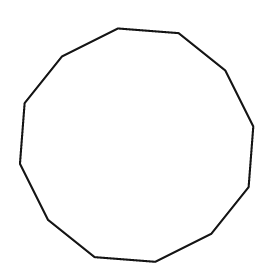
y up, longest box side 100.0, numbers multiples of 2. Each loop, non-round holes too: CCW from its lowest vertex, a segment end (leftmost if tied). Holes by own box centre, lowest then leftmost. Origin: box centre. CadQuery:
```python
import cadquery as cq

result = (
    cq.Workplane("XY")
    .moveTo(8.0, -50.0)
    .lineTo(32.0, -38.0)
    .lineTo(48.0, -18.0)
    .lineTo(50.0, 8.0)
    .lineTo(38.0, 32.0)
    .lineTo(18.0, 48.0)
    .lineTo(-8.0, 50.0)
    .lineTo(-32.0, 38.0)
    .lineTo(-48.0, 18.0)
    .lineTo(-50.0, -8.0)
    .lineTo(-38.0, -32.0)
    .lineTo(-18.0, -48.0)
    .close()
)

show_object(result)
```